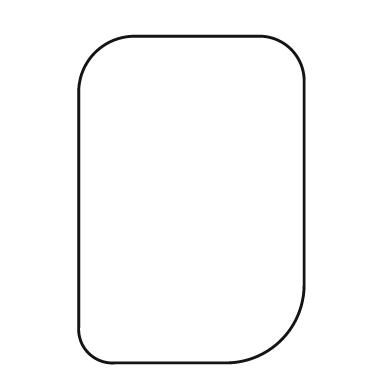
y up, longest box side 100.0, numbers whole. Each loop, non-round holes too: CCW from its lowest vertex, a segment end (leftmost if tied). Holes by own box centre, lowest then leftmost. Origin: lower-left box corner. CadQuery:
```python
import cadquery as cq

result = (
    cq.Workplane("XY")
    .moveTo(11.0, 0.0)
    .lineTo(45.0, 0.0)
    .threePointArc((62.0, 7.0), (69.0, 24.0))
    .lineTo(69.0, 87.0)
    .threePointArc((65.0, 96.0), (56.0, 100.0))
    .lineTo(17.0, 100.0)
    .threePointArc((5.0, 95.0), (0.0, 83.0))
    .lineTo(0.0, 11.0)
    .threePointArc((3.0, 3.0), (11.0, 0.0))
    .close()
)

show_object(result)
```